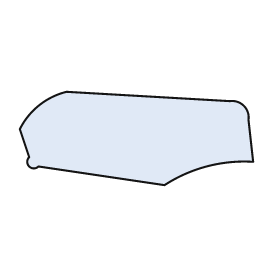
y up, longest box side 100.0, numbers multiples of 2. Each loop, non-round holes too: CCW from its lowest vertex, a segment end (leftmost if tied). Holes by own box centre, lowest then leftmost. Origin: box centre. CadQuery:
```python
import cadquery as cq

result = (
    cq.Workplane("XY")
    .moveTo(12.0, -20.0)
    .threePointArc((30.0, -12.0), (50.0, -10.0))
    .lineTo(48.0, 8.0)
    .threePointArc((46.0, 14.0), (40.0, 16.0))
    .lineTo(-30.0, 20.0)
    .threePointArc((-42.0, 14.0), (-50.0, 4.0))
    .lineTo(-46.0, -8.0)
    .threePointArc((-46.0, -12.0), (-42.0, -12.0))
    .close()
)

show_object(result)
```